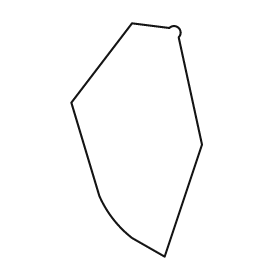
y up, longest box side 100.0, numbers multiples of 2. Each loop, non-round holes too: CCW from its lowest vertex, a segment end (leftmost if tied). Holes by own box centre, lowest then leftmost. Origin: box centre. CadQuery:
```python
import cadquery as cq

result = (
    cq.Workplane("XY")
    .moveTo(12.0, -50.0)
    .lineTo(28.0, -2.0)
    .lineTo(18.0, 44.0)
    .threePointArc((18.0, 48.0), (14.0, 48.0))
    .lineTo(-2.0, 50.0)
    .lineTo(-28.0, 16.0)
    .lineTo(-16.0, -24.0)
    .threePointArc((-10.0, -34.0), (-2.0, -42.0))
    .close()
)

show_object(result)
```